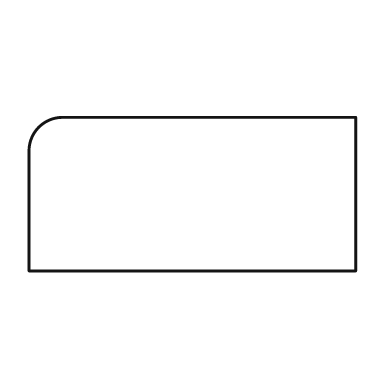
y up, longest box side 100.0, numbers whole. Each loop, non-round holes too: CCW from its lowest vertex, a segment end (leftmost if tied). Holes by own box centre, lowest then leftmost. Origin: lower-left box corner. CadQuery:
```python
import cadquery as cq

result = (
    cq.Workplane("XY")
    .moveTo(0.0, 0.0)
    .lineTo(100.0, 0.0)
    .lineTo(100.0, 47.0)
    .lineTo(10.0, 47.0)
    .threePointArc((3.0, 44.0), (0.0, 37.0))
    .close()
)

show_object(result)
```